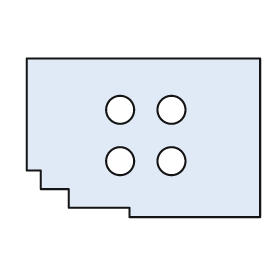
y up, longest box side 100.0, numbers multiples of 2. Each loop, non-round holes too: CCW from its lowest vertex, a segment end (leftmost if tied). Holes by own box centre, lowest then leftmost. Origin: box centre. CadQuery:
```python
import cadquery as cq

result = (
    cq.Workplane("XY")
    .moveTo(-6.0, -34.0)
    .lineTo(50.0, -34.0)
    .lineTo(50.0, 34.0)
    .lineTo(-50.0, 34.0)
    .lineTo(-50.0, -14.0)
    .lineTo(-44.0, -14.0)
    .lineTo(-44.0, -22.0)
    .lineTo(-32.0, -22.0)
    .lineTo(-32.0, -30.0)
    .lineTo(-6.0, -30.0)
    .close()
    .moveTo(-10.0, -10.0)
    .circle(6.0)
    .moveTo(12.0, -10.0)
    .circle(6.0)
    .moveTo(-10.0, 12.0)
    .circle(6.0)
    .moveTo(12.0, 12.0)
    .circle(6.0)
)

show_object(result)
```